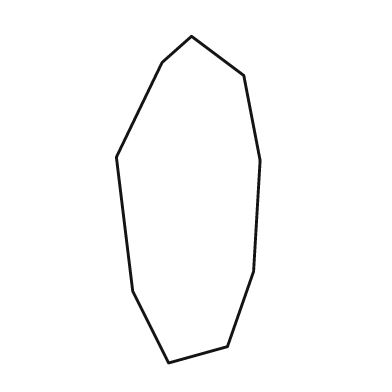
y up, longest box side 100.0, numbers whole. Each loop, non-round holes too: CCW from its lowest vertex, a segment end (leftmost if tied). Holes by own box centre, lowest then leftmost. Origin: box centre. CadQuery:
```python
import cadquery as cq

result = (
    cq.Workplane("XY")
    .moveTo(-6.0, -50.0)
    .lineTo(12.0, -45.0)
    .lineTo(20.0, -22.0)
    .lineTo(22.0, 12.0)
    .lineTo(17.0, 38.0)
    .lineTo(1.0, 50.0)
    .lineTo(-8.0, 42.0)
    .lineTo(-22.0, 13.0)
    .lineTo(-17.0, -28.0)
    .close()
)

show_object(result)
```